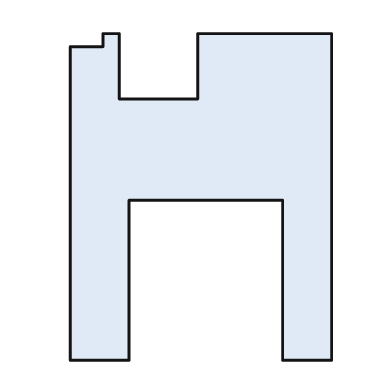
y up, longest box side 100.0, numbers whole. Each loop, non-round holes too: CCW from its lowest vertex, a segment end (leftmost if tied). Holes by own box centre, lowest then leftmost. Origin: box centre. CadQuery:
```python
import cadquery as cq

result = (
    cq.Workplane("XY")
    .moveTo(-40.0, -50.0)
    .lineTo(-22.0, -50.0)
    .lineTo(-22.0, -1.0)
    .lineTo(25.0, -1.0)
    .lineTo(25.0, -50.0)
    .lineTo(40.0, -50.0)
    .lineTo(40.0, 50.0)
    .lineTo(-1.0, 50.0)
    .lineTo(-1.0, 30.0)
    .lineTo(-25.0, 30.0)
    .lineTo(-25.0, 50.0)
    .lineTo(-30.0, 50.0)
    .lineTo(-30.0, 46.0)
    .lineTo(-40.0, 46.0)
    .close()
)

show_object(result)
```